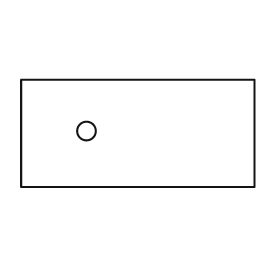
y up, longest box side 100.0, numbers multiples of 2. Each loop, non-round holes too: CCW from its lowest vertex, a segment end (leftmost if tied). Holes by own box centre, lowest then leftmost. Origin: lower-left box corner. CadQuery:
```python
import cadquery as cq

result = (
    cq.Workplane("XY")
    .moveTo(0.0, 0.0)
    .lineTo(100.0, 0.0)
    .lineTo(100.0, 46.0)
    .lineTo(0.0, 46.0)
    .close()
    .moveTo(28.0, 24.0)
    .circle(4.0)
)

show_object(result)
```